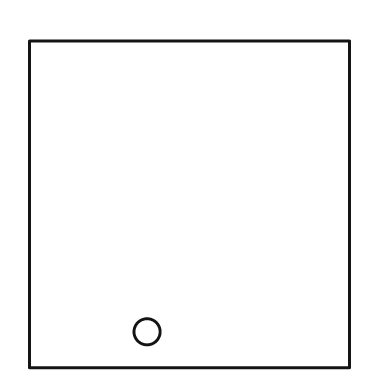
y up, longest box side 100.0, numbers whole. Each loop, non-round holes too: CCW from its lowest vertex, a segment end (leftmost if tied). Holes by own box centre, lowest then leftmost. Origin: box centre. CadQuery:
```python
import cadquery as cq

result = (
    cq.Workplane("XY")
    .moveTo(-49.0, -50.0)
    .lineTo(49.0, -50.0)
    .lineTo(49.0, 50.0)
    .lineTo(-49.0, 50.0)
    .close()
    .moveTo(-13.0, -39.0)
    .circle(4.0)
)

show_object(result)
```